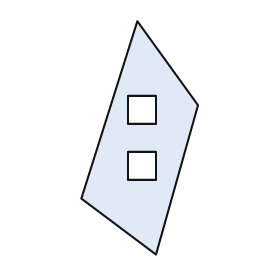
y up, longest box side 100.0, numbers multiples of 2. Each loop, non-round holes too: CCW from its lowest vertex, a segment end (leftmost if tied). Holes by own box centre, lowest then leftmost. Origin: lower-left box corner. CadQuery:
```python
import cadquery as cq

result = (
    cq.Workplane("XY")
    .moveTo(32.0, 0.0)
    .lineTo(50.0, 64.0)
    .lineTo(24.0, 100.0)
    .lineTo(0.0, 24.0)
    .close()
    .moveTo(20.0, 32.0)
    .lineTo(32.0, 32.0)
    .lineTo(32.0, 44.0)
    .lineTo(20.0, 44.0)
    .close()
    .moveTo(20.0, 56.0)
    .lineTo(32.0, 56.0)
    .lineTo(32.0, 68.0)
    .lineTo(20.0, 68.0)
    .close()
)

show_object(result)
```